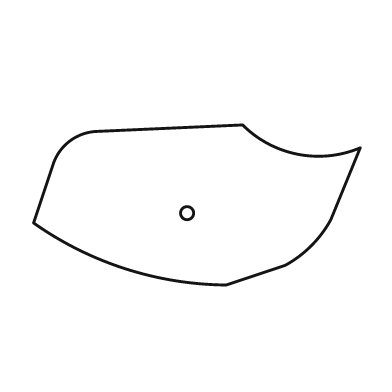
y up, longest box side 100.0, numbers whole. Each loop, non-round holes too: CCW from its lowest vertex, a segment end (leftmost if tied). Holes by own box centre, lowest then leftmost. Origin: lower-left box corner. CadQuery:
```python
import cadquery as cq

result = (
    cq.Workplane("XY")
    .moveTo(59.0, 0.0)
    .lineTo(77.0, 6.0)
    .threePointArc((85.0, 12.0), (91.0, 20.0))
    .lineTo(100.0, 42.0)
    .threePointArc((81.0, 40.0), (64.0, 49.0))
    .lineTo(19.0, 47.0)
    .threePointArc((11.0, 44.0), (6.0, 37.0))
    .lineTo(0.0, 19.0)
    .threePointArc((28.0, 5.0), (59.0, 0.0))
    .close()
    .moveTo(47.0, 22.0)
    .circle(2.0)
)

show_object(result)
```